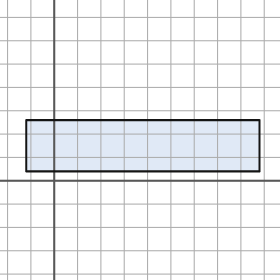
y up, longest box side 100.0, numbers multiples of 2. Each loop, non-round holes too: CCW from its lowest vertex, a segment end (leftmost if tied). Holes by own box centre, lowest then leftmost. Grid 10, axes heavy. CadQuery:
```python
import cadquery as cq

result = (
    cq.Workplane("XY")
    .moveTo(-12.0, 4.0)
    .lineTo(88.0, 4.0)
    .lineTo(88.0, 26.0)
    .lineTo(-12.0, 26.0)
    .close()
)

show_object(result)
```